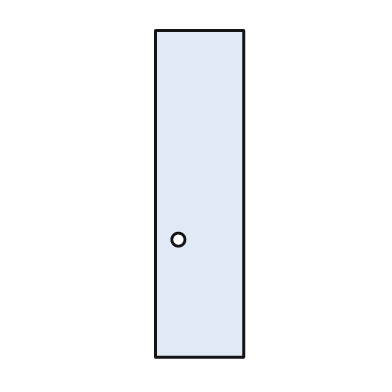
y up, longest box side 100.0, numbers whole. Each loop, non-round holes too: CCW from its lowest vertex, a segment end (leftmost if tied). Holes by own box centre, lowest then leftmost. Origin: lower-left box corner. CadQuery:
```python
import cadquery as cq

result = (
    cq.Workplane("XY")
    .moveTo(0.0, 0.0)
    .lineTo(27.0, 0.0)
    .lineTo(27.0, 100.0)
    .lineTo(0.0, 100.0)
    .close()
    .moveTo(7.0, 36.0)
    .circle(2.0)
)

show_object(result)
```